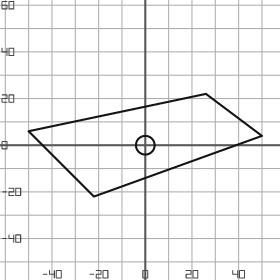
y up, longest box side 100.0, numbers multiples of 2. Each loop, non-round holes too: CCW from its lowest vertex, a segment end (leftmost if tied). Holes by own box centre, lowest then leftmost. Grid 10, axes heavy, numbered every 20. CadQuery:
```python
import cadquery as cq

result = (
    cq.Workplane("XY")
    .moveTo(-22.0, -22.0)
    .lineTo(50.0, 4.0)
    .lineTo(26.0, 22.0)
    .lineTo(-50.0, 6.0)
    .close()
    .moveTo(0.0, 0.0)
    .circle(4.0)
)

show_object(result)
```